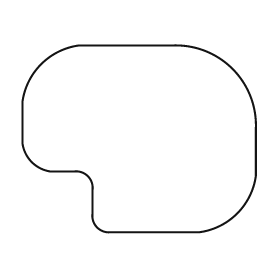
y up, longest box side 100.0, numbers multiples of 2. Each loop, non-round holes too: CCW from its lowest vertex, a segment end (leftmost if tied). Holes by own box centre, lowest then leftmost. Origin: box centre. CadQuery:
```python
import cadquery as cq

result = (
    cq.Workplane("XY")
    .moveTo(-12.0, -40.0)
    .lineTo(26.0, -40.0)
    .threePointArc((42.0, -32.0), (50.0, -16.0))
    .lineTo(50.0, 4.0)
    .threePointArc((40.0, 30.0), (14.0, 40.0))
    .lineTo(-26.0, 40.0)
    .threePointArc((-42.0, 32.0), (-50.0, 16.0))
    .lineTo(-50.0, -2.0)
    .threePointArc((-46.0, -10.0), (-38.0, -14.0))
    .lineTo(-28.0, -14.0)
    .threePointArc((-22.0, -16.0), (-20.0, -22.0))
    .lineTo(-20.0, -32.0)
    .threePointArc((-18.0, -38.0), (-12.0, -40.0))
    .close()
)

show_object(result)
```